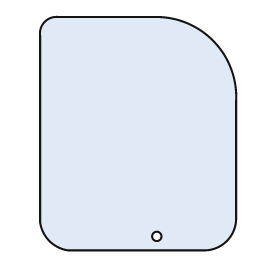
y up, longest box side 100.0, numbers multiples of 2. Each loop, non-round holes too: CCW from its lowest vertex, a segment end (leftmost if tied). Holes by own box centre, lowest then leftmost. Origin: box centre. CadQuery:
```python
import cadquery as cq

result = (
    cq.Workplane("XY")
    .moveTo(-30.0, -50.0)
    .lineTo(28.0, -50.0)
    .threePointArc((38.0, -46.0), (42.0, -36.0))
    .lineTo(42.0, 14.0)
    .threePointArc((32.0, 40.0), (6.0, 50.0))
    .lineTo(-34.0, 50.0)
    .threePointArc((-40.0, 48.0), (-42.0, 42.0))
    .lineTo(-42.0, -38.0)
    .threePointArc((-38.0, -46.0), (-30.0, -50.0))
    .close()
    .moveTo(8.0, -44.0)
    .circle(2.0)
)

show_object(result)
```